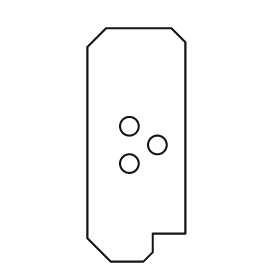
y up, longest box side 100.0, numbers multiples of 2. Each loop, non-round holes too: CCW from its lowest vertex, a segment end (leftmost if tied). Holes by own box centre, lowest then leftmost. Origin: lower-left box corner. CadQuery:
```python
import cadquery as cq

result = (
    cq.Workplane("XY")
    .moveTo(10.0, 0.0)
    .lineTo(24.0, 0.0)
    .lineTo(28.0, 4.0)
    .lineTo(28.0, 12.0)
    .lineTo(42.0, 12.0)
    .lineTo(42.0, 94.0)
    .lineTo(36.0, 100.0)
    .lineTo(8.0, 100.0)
    .lineTo(0.0, 92.0)
    .lineTo(0.0, 10.0)
    .close()
    .moveTo(18.0, 42.0)
    .circle(4.0)
    .moveTo(30.0, 50.0)
    .circle(4.0)
    .moveTo(18.0, 58.0)
    .circle(4.0)
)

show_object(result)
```